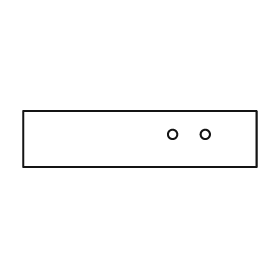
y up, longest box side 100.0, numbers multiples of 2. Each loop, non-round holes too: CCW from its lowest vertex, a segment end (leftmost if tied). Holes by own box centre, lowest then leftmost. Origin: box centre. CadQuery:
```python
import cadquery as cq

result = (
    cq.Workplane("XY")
    .moveTo(-50.0, -12.0)
    .lineTo(50.0, -12.0)
    .lineTo(50.0, 12.0)
    .lineTo(-50.0, 12.0)
    .close()
    .moveTo(14.0, 2.0)
    .circle(2.0)
    .moveTo(28.0, 2.0)
    .circle(2.0)
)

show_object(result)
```